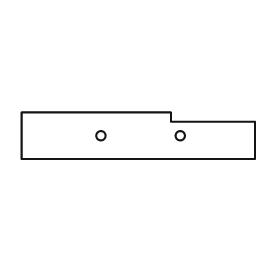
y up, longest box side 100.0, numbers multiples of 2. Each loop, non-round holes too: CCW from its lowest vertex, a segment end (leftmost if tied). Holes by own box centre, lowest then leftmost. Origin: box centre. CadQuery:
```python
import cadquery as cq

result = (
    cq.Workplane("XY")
    .moveTo(-50.0, -10.0)
    .lineTo(50.0, -10.0)
    .lineTo(50.0, 6.0)
    .lineTo(14.0, 6.0)
    .lineTo(14.0, 10.0)
    .lineTo(-50.0, 10.0)
    .close()
    .moveTo(-16.0, 0.0)
    .circle(2.0)
    .moveTo(18.0, 0.0)
    .circle(2.0)
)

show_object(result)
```